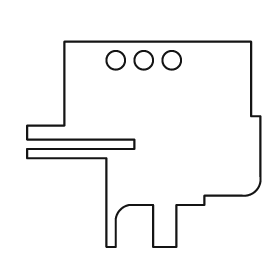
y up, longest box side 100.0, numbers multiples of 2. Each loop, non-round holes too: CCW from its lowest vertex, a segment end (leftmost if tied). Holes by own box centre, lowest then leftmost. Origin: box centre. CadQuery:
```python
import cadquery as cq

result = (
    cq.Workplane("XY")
    .moveTo(-16.0, -44.0)
    .lineTo(-12.0, -44.0)
    .lineTo(-12.0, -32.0)
    .threePointArc((-10.0, -28.0), (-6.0, -26.0))
    .lineTo(4.0, -26.0)
    .lineTo(4.0, -44.0)
    .lineTo(14.0, -44.0)
    .lineTo(14.0, -26.0)
    .lineTo(26.0, -26.0)
    .lineTo(26.0, -22.0)
    .lineTo(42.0, -22.0)
    .threePointArc((48.0, -20.0), (50.0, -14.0))
    .lineTo(50.0, 12.0)
    .lineTo(46.0, 12.0)
    .lineTo(46.0, 44.0)
    .lineTo(-34.0, 44.0)
    .lineTo(-34.0, 8.0)
    .lineTo(-50.0, 8.0)
    .lineTo(-50.0, 2.0)
    .lineTo(-4.0, 2.0)
    .lineTo(-4.0, -2.0)
    .lineTo(-50.0, -2.0)
    .lineTo(-50.0, -6.0)
    .lineTo(-16.0, -6.0)
    .close()
    .moveTo(-12.0, 36.0)
    .circle(4.0)
    .moveTo(0.0, 36.0)
    .circle(4.0)
    .moveTo(12.0, 36.0)
    .circle(4.0)
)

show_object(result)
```